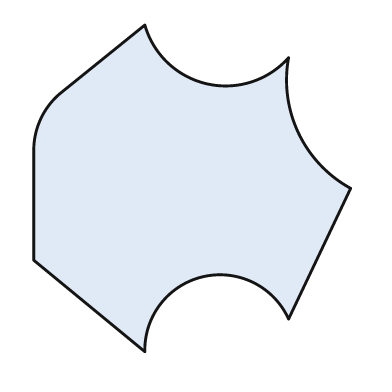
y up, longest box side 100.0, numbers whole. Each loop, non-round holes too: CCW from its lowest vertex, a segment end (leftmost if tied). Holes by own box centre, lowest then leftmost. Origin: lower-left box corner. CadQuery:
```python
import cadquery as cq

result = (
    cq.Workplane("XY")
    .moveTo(34.0, 0.0)
    .threePointArc((52.0, 23.0), (78.0, 10.0))
    .lineTo(97.0, 50.0)
    .threePointArc((81.0, 67.0), (78.0, 90.0))
    .threePointArc((53.0, 82.0), (34.0, 100.0))
    .lineTo(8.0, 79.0)
    .threePointArc((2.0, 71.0), (0.0, 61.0))
    .lineTo(0.0, 28.0)
    .close()
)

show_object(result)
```